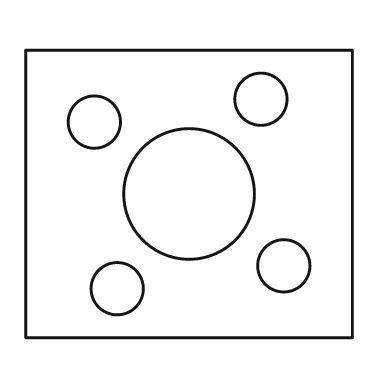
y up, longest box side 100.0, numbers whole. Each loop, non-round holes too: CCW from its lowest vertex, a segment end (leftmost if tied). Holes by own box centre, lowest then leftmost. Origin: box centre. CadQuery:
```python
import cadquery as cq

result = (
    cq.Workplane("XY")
    .moveTo(-50.0, -44.0)
    .lineTo(50.0, -44.0)
    .lineTo(50.0, 44.0)
    .lineTo(-50.0, 44.0)
    .close()
    .moveTo(-22.0, -29.0)
    .circle(8.0)
    .moveTo(29.0, -22.0)
    .circle(8.0)
    .moveTo(0.0, 0.0)
    .circle(20.0)
    .moveTo(-29.0, 22.0)
    .circle(8.0)
    .moveTo(22.0, 29.0)
    .circle(8.0)
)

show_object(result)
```